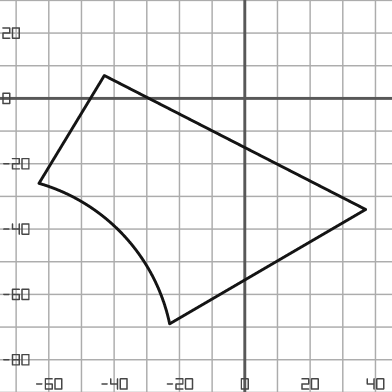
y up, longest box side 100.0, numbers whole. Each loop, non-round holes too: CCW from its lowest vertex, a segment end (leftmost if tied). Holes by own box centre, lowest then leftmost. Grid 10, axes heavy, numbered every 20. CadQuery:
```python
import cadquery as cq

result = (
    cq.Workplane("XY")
    .moveTo(-23.0, -69.0)
    .lineTo(37.0, -34.0)
    .lineTo(-43.0, 7.0)
    .lineTo(-63.0, -26.0)
    .threePointArc((-37.0, -42.0), (-23.0, -69.0))
    .close()
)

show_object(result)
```